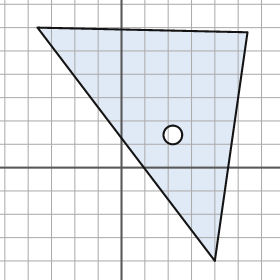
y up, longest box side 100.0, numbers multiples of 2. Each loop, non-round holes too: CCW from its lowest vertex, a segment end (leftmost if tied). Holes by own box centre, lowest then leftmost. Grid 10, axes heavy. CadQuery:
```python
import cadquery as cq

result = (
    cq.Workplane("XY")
    .moveTo(40.0, -40.0)
    .lineTo(54.0, 58.0)
    .lineTo(-36.0, 60.0)
    .close()
    .moveTo(22.0, 14.0)
    .circle(4.0)
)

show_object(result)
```